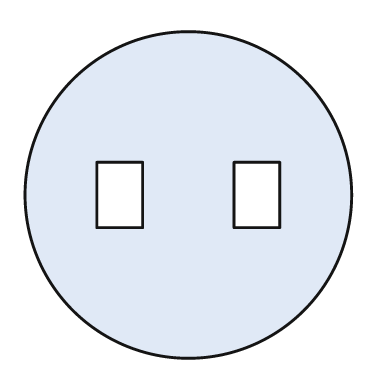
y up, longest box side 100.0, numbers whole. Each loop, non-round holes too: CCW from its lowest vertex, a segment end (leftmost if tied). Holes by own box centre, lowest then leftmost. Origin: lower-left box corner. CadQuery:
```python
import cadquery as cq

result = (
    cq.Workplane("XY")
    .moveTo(50.0, 50.0)
    .circle(50.0)
    .moveTo(22.0, 40.0)
    .lineTo(36.0, 40.0)
    .lineTo(36.0, 60.0)
    .lineTo(22.0, 60.0)
    .close()
    .moveTo(64.0, 40.0)
    .lineTo(78.0, 40.0)
    .lineTo(78.0, 60.0)
    .lineTo(64.0, 60.0)
    .close()
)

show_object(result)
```